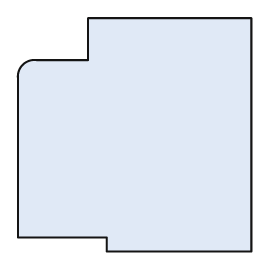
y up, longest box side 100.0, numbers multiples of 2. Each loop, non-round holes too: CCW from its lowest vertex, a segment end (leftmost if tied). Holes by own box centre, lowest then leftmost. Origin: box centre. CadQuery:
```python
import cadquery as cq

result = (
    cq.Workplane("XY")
    .moveTo(-12.0, -50.0)
    .lineTo(50.0, -50.0)
    .lineTo(50.0, 50.0)
    .lineTo(-20.0, 50.0)
    .lineTo(-20.0, 32.0)
    .lineTo(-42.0, 32.0)
    .threePointArc((-48.0, 30.0), (-50.0, 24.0))
    .lineTo(-50.0, -44.0)
    .lineTo(-12.0, -44.0)
    .close()
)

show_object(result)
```